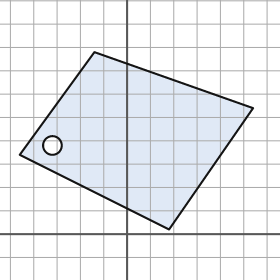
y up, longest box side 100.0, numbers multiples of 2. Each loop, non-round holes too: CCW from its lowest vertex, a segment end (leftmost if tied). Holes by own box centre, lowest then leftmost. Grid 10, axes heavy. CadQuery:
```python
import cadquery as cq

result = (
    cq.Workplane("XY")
    .moveTo(18.0, 2.0)
    .lineTo(54.0, 54.0)
    .lineTo(-14.0, 78.0)
    .lineTo(-46.0, 34.0)
    .close()
    .moveTo(-32.0, 38.0)
    .circle(4.0)
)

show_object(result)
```